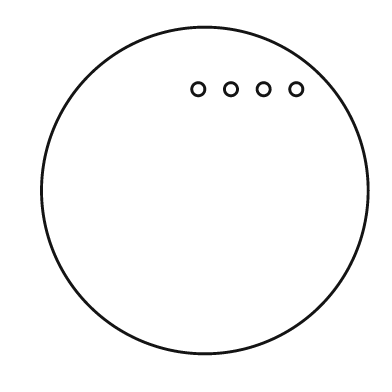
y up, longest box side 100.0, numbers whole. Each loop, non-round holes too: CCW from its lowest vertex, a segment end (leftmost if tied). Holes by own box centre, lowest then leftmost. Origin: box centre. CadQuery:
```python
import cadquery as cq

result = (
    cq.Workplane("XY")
    .moveTo(0.0, 0.0)
    .circle(50.0)
    .moveTo(-2.0, 31.0)
    .circle(2.0)
    .moveTo(8.0, 31.0)
    .circle(2.0)
    .moveTo(18.0, 31.0)
    .circle(2.0)
    .moveTo(28.0, 31.0)
    .circle(2.0)
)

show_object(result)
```